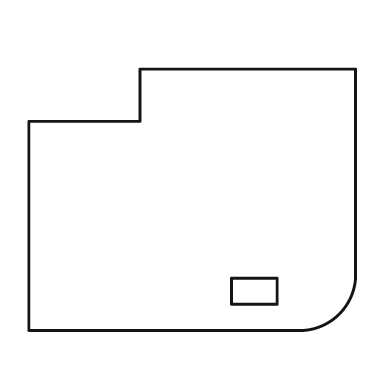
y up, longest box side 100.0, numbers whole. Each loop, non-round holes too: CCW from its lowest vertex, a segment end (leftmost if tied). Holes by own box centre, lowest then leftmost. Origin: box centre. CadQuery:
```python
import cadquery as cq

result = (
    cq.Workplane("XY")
    .moveTo(-50.0, -40.0)
    .lineTo(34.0, -40.0)
    .threePointArc((45.0, -35.0), (50.0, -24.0))
    .lineTo(50.0, 40.0)
    .lineTo(-16.0, 40.0)
    .lineTo(-16.0, 24.0)
    .lineTo(-50.0, 24.0)
    .close()
    .moveTo(12.0, -32.0)
    .lineTo(26.0, -32.0)
    .lineTo(26.0, -24.0)
    .lineTo(12.0, -24.0)
    .close()
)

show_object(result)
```